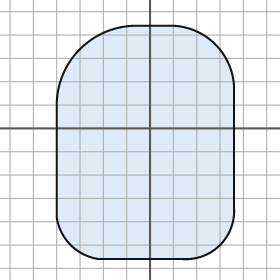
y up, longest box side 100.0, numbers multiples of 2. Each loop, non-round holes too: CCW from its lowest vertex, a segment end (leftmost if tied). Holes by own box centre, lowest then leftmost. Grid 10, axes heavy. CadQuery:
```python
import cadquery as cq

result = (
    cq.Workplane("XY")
    .moveTo(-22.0, -56.0)
    .lineTo(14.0, -56.0)
    .threePointArc((30.0, -50.0), (36.0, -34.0))
    .lineTo(36.0, 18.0)
    .threePointArc((28.0, 36.0), (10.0, 44.0))
    .lineTo(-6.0, 44.0)
    .threePointArc((-30.0, 34.0), (-40.0, 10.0))
    .lineTo(-40.0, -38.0)
    .threePointArc((-34.0, -50.0), (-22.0, -56.0))
    .close()
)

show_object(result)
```